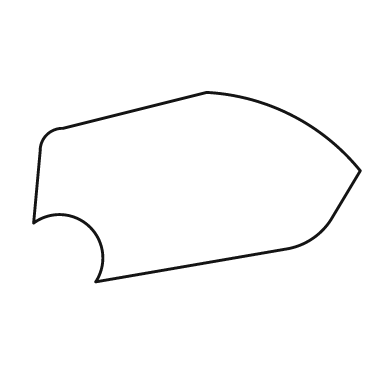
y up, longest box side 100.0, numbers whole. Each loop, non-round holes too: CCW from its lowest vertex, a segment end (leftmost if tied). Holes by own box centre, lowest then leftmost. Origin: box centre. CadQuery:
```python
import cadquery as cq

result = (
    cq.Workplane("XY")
    .moveTo(-31.0, -29.0)
    .lineTo(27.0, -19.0)
    .threePointArc((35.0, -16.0), (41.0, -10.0))
    .lineTo(50.0, 5.0)
    .threePointArc((29.0, 22.0), (3.0, 29.0))
    .lineTo(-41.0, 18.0)
    .threePointArc((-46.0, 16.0), (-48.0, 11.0))
    .lineTo(-50.0, -11.0)
    .threePointArc((-33.0, -12.0), (-31.0, -29.0))
    .close()
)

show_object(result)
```